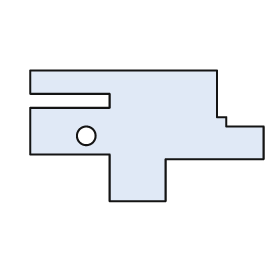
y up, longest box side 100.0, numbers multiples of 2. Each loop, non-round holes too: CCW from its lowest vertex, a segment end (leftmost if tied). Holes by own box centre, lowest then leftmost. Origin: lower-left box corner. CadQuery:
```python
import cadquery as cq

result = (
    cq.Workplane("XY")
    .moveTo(34.0, 0.0)
    .lineTo(58.0, 0.0)
    .lineTo(58.0, 18.0)
    .lineTo(100.0, 18.0)
    .lineTo(100.0, 32.0)
    .lineTo(84.0, 32.0)
    .lineTo(84.0, 36.0)
    .lineTo(80.0, 36.0)
    .lineTo(80.0, 56.0)
    .lineTo(0.0, 56.0)
    .lineTo(0.0, 46.0)
    .lineTo(34.0, 46.0)
    .lineTo(34.0, 40.0)
    .lineTo(0.0, 40.0)
    .lineTo(0.0, 20.0)
    .lineTo(34.0, 20.0)
    .close()
    .moveTo(24.0, 28.0)
    .circle(4.0)
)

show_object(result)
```